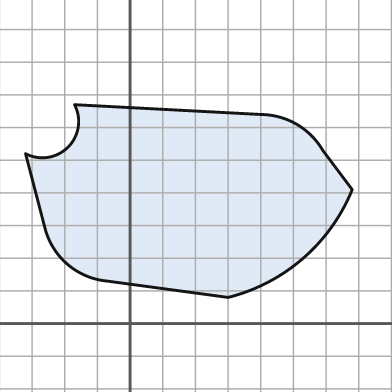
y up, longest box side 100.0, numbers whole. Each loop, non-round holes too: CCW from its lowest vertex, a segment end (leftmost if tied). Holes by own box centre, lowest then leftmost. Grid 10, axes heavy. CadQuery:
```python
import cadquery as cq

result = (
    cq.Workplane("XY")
    .moveTo(30.0, 8.0)
    .threePointArc((53.0, 20.0), (68.0, 41.0))
    .lineTo(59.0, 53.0)
    .threePointArc((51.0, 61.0), (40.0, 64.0))
    .lineTo(-17.0, 67.0)
    .threePointArc((-19.0, 54.0), (-32.0, 52.0))
    .lineTo(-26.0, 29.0)
    .threePointArc((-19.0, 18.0), (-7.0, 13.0))
    .close()
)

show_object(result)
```